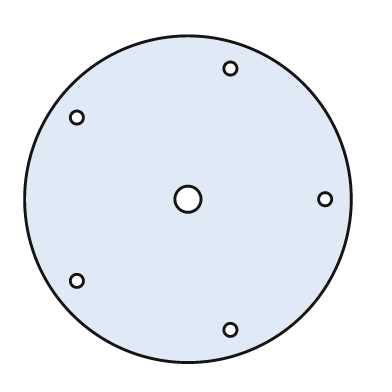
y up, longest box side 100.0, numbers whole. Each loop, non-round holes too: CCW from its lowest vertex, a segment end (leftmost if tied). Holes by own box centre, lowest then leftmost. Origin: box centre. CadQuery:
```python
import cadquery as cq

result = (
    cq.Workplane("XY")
    .moveTo(0.0, 0.0)
    .circle(50.0)
    .moveTo(13.0, -40.0)
    .circle(2.0)
    .moveTo(-34.0, -25.0)
    .circle(2.0)
    .moveTo(0.0, 0.0)
    .circle(4.0)
    .moveTo(42.0, 0.0)
    .circle(2.0)
    .moveTo(-34.0, 25.0)
    .circle(2.0)
    .moveTo(13.0, 40.0)
    .circle(2.0)
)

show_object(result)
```